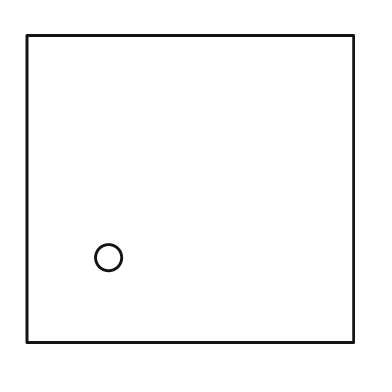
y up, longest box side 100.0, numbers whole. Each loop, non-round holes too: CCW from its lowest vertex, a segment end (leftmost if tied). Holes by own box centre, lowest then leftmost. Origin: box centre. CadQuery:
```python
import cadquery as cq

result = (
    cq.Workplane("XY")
    .moveTo(-50.0, -47.0)
    .lineTo(50.0, -47.0)
    .lineTo(50.0, 47.0)
    .lineTo(-50.0, 47.0)
    .close()
    .moveTo(-25.0, -21.0)
    .circle(4.0)
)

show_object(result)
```